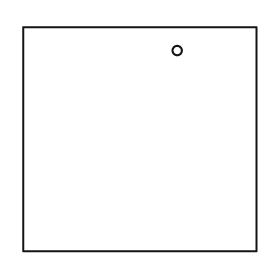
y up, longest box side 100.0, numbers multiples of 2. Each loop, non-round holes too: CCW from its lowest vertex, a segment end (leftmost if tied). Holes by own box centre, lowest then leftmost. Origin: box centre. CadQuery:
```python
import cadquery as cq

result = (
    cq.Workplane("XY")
    .moveTo(-50.0, -48.0)
    .lineTo(50.0, -48.0)
    .lineTo(50.0, 48.0)
    .lineTo(-50.0, 48.0)
    .close()
    .moveTo(16.0, 38.0)
    .circle(2.0)
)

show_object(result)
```